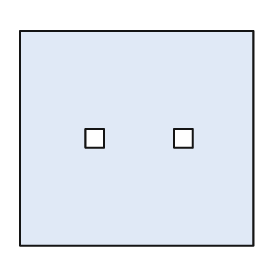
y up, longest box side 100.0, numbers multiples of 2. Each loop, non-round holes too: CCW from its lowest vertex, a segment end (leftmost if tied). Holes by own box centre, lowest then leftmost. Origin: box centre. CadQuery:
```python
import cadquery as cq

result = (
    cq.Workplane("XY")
    .moveTo(-50.0, -46.0)
    .lineTo(50.0, -46.0)
    .lineTo(50.0, 46.0)
    .lineTo(-50.0, 46.0)
    .close()
    .moveTo(-22.0, -4.0)
    .lineTo(-14.0, -4.0)
    .lineTo(-14.0, 4.0)
    .lineTo(-22.0, 4.0)
    .close()
    .moveTo(16.0, -4.0)
    .lineTo(24.0, -4.0)
    .lineTo(24.0, 4.0)
    .lineTo(16.0, 4.0)
    .close()
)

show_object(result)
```